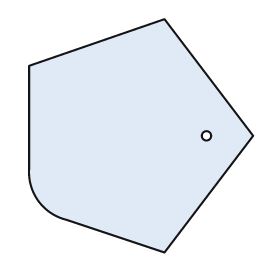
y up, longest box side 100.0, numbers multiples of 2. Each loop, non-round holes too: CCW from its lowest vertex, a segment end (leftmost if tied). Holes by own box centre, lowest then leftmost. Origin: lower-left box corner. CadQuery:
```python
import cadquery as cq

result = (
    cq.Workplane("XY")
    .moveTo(58.0, 0.0)
    .lineTo(96.0, 50.0)
    .lineTo(58.0, 100.0)
    .lineTo(0.0, 80.0)
    .lineTo(0.0, 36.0)
    .threePointArc((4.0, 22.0), (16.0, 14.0))
    .close()
    .moveTo(76.0, 50.0)
    .circle(2.0)
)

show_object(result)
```